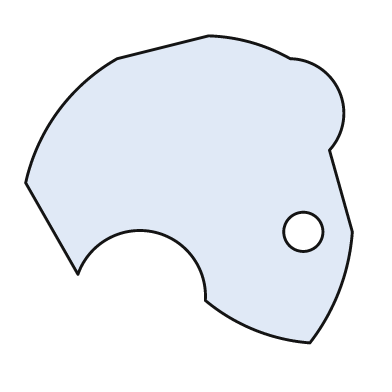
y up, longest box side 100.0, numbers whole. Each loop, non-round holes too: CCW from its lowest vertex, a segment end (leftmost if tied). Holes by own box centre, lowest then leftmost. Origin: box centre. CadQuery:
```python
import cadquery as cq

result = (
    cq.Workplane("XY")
    .moveTo(37.0, -47.0)
    .threePointArc((46.0, -31.0), (50.0, -13.0))
    .lineTo(43.0, 12.0)
    .threePointArc((46.0, 30.0), (31.0, 40.0))
    .threePointArc((19.0, 45.0), (6.0, 47.0))
    .lineTo(-22.0, 40.0)
    .threePointArc((-40.0, 24.0), (-50.0, 2.0))
    .lineTo(-34.0, -26.0)
    .threePointArc((-11.0, -13.0), (5.0, -34.0))
    .threePointArc((20.0, -43.0), (37.0, -47.0))
    .close()
    .moveTo(35.0, -13.0)
    .circle(6.0)
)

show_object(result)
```